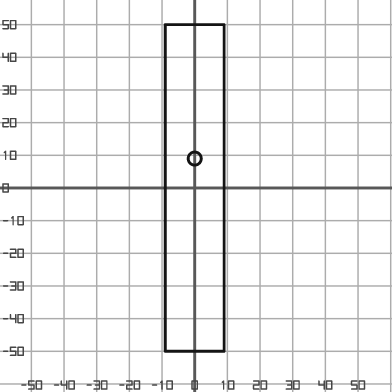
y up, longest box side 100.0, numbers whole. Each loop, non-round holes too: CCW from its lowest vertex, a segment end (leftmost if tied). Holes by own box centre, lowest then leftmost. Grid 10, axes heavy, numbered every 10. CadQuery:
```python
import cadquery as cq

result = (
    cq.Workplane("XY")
    .moveTo(-9.0, -50.0)
    .lineTo(9.0, -50.0)
    .lineTo(9.0, 50.0)
    .lineTo(-9.0, 50.0)
    .close()
    .moveTo(0.0, 9.0)
    .circle(2.0)
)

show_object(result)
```